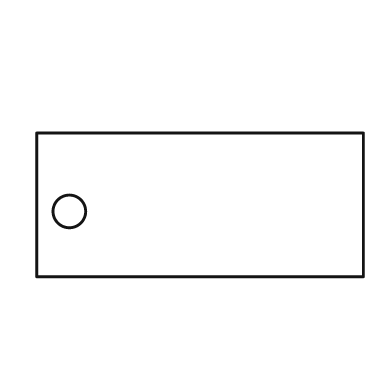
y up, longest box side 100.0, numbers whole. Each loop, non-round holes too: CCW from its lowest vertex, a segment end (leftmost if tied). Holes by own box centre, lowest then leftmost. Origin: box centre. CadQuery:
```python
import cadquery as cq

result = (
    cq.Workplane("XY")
    .moveTo(-50.0, -22.0)
    .lineTo(50.0, -22.0)
    .lineTo(50.0, 22.0)
    .lineTo(-50.0, 22.0)
    .close()
    .moveTo(-40.0, -2.0)
    .circle(5.0)
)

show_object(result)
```